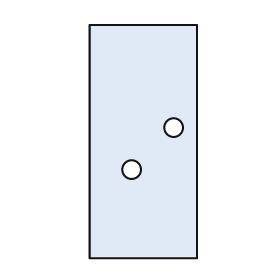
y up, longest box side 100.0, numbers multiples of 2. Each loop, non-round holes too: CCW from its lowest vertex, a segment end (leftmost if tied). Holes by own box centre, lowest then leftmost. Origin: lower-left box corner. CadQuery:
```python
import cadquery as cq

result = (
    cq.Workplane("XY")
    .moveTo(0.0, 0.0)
    .lineTo(46.0, 0.0)
    .lineTo(46.0, 100.0)
    .lineTo(0.0, 100.0)
    .close()
    .moveTo(18.0, 38.0)
    .circle(4.0)
    .moveTo(36.0, 56.0)
    .circle(4.0)
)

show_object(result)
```